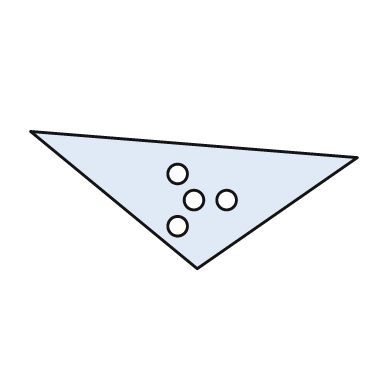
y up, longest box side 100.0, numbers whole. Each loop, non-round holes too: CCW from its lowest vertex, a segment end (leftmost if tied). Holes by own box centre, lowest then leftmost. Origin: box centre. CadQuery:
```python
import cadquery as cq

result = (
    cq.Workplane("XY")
    .moveTo(1.0, -21.0)
    .lineTo(50.0, 13.0)
    .lineTo(-50.0, 21.0)
    .close()
    .moveTo(-5.0, -8.0)
    .circle(3.0)
    .moveTo(0.0, 0.0)
    .circle(3.0)
    .moveTo(10.0, 0.0)
    .circle(3.0)
    .moveTo(-5.0, 8.0)
    .circle(3.0)
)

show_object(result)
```